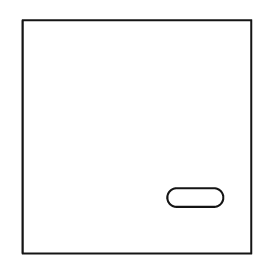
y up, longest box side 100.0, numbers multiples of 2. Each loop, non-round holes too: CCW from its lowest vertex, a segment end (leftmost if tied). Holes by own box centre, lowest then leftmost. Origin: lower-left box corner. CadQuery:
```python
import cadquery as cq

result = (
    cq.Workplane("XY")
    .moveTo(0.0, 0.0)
    .lineTo(98.0, 0.0)
    .lineTo(98.0, 100.0)
    .lineTo(0.0, 100.0)
    .close()
    .moveTo(66.0, 20.0)
    .lineTo(82.0, 20.0)
    .threePointArc((86.0, 24.0), (82.0, 28.0))
    .lineTo(66.0, 28.0)
    .threePointArc((62.0, 24.0), (66.0, 20.0))
    .close()
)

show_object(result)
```